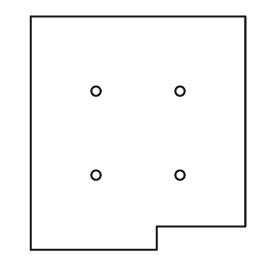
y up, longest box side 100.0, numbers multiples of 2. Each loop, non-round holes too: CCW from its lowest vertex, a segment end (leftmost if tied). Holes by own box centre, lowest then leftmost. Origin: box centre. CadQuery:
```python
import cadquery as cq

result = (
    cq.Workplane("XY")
    .moveTo(-46.0, -50.0)
    .lineTo(8.0, -50.0)
    .lineTo(8.0, -40.0)
    .lineTo(46.0, -40.0)
    .lineTo(46.0, 50.0)
    .lineTo(-46.0, 50.0)
    .close()
    .moveTo(-18.0, -18.0)
    .circle(2.0)
    .moveTo(18.0, -18.0)
    .circle(2.0)
    .moveTo(-18.0, 18.0)
    .circle(2.0)
    .moveTo(18.0, 18.0)
    .circle(2.0)
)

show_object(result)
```